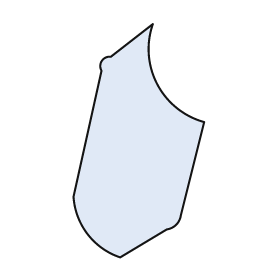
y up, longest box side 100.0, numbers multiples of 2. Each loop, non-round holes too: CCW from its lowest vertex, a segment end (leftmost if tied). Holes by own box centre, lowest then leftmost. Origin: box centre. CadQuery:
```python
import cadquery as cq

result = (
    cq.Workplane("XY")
    .moveTo(-8.0, -50.0)
    .lineTo(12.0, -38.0)
    .threePointArc((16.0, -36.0), (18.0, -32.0))
    .lineTo(28.0, 8.0)
    .threePointArc((8.0, 24.0), (6.0, 50.0))
    .lineTo(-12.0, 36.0)
    .threePointArc((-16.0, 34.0), (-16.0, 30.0))
    .lineTo(-28.0, -24.0)
    .threePointArc((-22.0, -40.0), (-8.0, -50.0))
    .close()
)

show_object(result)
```